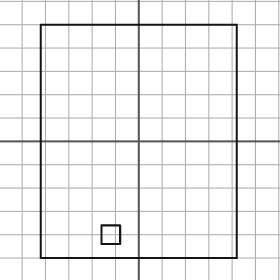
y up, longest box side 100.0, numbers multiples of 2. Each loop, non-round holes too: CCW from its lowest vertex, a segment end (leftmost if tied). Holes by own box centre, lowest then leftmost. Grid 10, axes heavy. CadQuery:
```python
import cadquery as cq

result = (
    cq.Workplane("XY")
    .moveTo(-42.0, -50.0)
    .lineTo(42.0, -50.0)
    .lineTo(42.0, 50.0)
    .lineTo(-42.0, 50.0)
    .close()
    .moveTo(-16.0, -44.0)
    .lineTo(-8.0, -44.0)
    .lineTo(-8.0, -36.0)
    .lineTo(-16.0, -36.0)
    .close()
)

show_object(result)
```